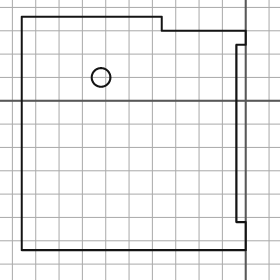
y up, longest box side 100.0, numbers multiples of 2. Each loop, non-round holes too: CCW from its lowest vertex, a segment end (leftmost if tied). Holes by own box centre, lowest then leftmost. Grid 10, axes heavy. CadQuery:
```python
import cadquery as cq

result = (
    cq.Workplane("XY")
    .moveTo(-96.0, -64.0)
    .lineTo(0.0, -64.0)
    .lineTo(0.0, -52.0)
    .lineTo(-4.0, -52.0)
    .lineTo(-4.0, 24.0)
    .lineTo(0.0, 24.0)
    .lineTo(0.0, 30.0)
    .lineTo(-36.0, 30.0)
    .lineTo(-36.0, 36.0)
    .lineTo(-96.0, 36.0)
    .close()
    .moveTo(-62.0, 10.0)
    .circle(4.0)
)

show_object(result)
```